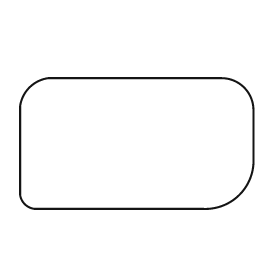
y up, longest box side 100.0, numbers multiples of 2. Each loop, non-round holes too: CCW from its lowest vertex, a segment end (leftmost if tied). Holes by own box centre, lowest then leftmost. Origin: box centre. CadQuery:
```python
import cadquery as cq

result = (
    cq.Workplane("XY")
    .moveTo(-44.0, -28.0)
    .lineTo(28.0, -28.0)
    .threePointArc((44.0, -22.0), (50.0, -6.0))
    .lineTo(50.0, 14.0)
    .threePointArc((46.0, 24.0), (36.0, 28.0))
    .lineTo(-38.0, 28.0)
    .threePointArc((-46.0, 24.0), (-50.0, 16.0))
    .lineTo(-50.0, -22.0)
    .threePointArc((-48.0, -26.0), (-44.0, -28.0))
    .close()
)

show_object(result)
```